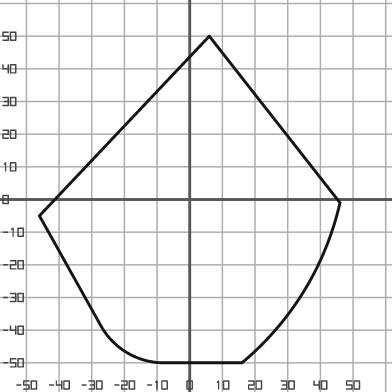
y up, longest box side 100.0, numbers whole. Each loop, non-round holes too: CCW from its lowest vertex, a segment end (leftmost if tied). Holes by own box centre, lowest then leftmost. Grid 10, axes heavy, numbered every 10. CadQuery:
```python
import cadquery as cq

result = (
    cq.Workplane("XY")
    .moveTo(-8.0, -50.0)
    .lineTo(16.0, -50.0)
    .threePointArc((35.0, -28.0), (46.0, -1.0))
    .lineTo(6.0, 50.0)
    .lineTo(-46.0, -5.0)
    .lineTo(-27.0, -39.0)
    .threePointArc((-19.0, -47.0), (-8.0, -50.0))
    .close()
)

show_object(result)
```